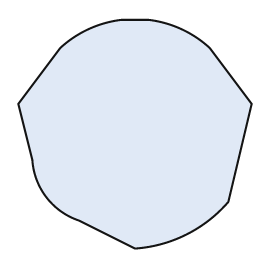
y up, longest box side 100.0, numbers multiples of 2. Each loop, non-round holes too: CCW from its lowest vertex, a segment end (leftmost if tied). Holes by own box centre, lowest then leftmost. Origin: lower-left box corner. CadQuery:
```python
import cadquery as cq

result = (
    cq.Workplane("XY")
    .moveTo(50.0, 0.0)
    .threePointArc((72.0, 6.0), (90.0, 20.0))
    .lineTo(100.0, 62.0)
    .lineTo(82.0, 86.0)
    .threePointArc((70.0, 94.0), (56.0, 98.0))
    .lineTo(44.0, 98.0)
    .threePointArc((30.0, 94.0), (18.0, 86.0))
    .lineTo(0.0, 62.0)
    .lineTo(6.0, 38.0)
    .threePointArc((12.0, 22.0), (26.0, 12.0))
    .close()
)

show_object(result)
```